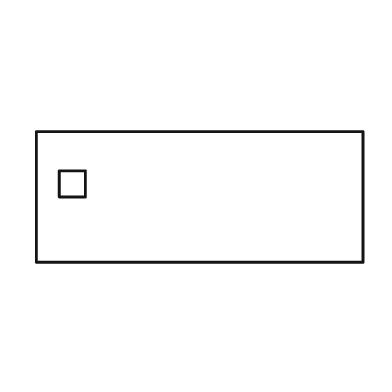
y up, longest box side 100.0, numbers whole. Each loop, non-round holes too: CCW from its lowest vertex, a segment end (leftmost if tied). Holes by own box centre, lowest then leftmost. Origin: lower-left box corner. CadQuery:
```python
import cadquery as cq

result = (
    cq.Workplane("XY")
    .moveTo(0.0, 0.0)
    .lineTo(100.0, 0.0)
    .lineTo(100.0, 40.0)
    .lineTo(0.0, 40.0)
    .close()
    .moveTo(7.0, 20.0)
    .lineTo(15.0, 20.0)
    .lineTo(15.0, 28.0)
    .lineTo(7.0, 28.0)
    .close()
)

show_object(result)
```